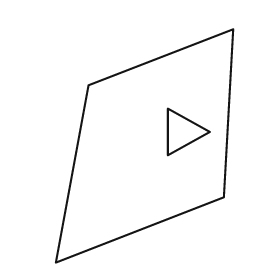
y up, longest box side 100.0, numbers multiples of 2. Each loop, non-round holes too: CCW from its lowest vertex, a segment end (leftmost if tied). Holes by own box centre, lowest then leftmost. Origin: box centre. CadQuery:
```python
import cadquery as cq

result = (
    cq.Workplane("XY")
    .moveTo(-38.0, -50.0)
    .lineTo(34.0, -22.0)
    .lineTo(38.0, 50.0)
    .lineTo(-24.0, 26.0)
    .close()
    .moveTo(10.0, -4.0)
    .lineTo(28.0, 6.0)
    .lineTo(10.0, 16.0)
    .close()
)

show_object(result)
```